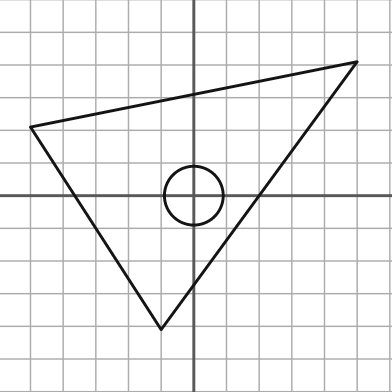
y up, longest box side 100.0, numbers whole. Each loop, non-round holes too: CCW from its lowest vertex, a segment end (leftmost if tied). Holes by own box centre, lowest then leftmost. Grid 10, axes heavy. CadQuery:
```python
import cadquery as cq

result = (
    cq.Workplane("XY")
    .moveTo(-10.0, -41.0)
    .lineTo(50.0, 41.0)
    .lineTo(-50.0, 21.0)
    .close()
    .moveTo(0.0, 0.0)
    .circle(9.0)
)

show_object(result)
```